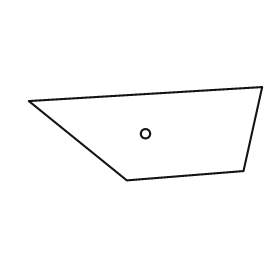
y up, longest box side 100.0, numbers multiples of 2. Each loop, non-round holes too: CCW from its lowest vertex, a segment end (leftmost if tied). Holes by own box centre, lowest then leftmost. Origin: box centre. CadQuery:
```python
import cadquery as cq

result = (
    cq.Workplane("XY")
    .moveTo(-8.0, -20.0)
    .lineTo(42.0, -16.0)
    .lineTo(50.0, 20.0)
    .lineTo(-50.0, 14.0)
    .close()
    .moveTo(0.0, 0.0)
    .circle(2.0)
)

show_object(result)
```